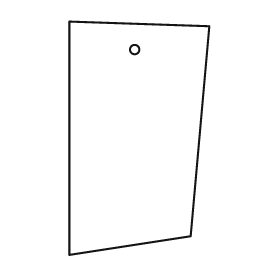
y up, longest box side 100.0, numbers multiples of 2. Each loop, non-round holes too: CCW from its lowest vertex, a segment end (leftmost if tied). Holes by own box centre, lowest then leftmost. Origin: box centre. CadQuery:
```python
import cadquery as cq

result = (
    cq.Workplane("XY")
    .moveTo(-30.0, -50.0)
    .lineTo(22.0, -42.0)
    .lineTo(30.0, 48.0)
    .lineTo(-30.0, 50.0)
    .close()
    .moveTo(-2.0, 38.0)
    .circle(2.0)
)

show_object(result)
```